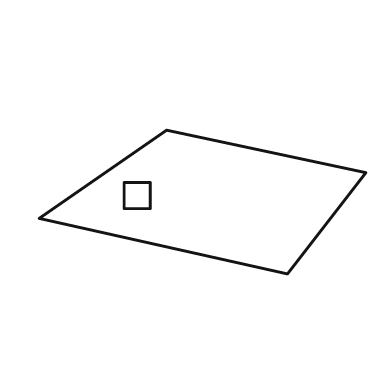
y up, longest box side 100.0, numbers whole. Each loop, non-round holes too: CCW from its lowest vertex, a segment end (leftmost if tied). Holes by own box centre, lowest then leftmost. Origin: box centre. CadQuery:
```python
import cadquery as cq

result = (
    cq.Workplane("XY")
    .moveTo(26.0, -22.0)
    .lineTo(50.0, 9.0)
    .lineTo(-11.0, 22.0)
    .lineTo(-50.0, -5.0)
    .close()
    .moveTo(-24.0, -2.0)
    .lineTo(-16.0, -2.0)
    .lineTo(-16.0, 6.0)
    .lineTo(-24.0, 6.0)
    .close()
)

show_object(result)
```